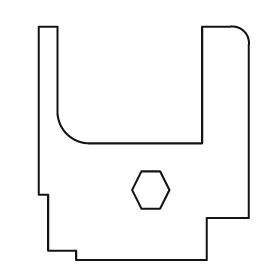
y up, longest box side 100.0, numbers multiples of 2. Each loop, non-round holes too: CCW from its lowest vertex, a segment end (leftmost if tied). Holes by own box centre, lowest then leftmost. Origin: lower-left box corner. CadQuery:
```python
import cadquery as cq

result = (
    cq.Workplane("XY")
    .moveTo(16.0, 0.0)
    .lineTo(72.0, 0.0)
    .lineTo(72.0, 18.0)
    .lineTo(90.0, 18.0)
    .lineTo(90.0, 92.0)
    .threePointArc((88.0, 98.0), (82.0, 100.0))
    .lineTo(70.0, 100.0)
    .lineTo(70.0, 50.0)
    .lineTo(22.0, 50.0)
    .threePointArc((12.0, 54.0), (8.0, 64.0))
    .lineTo(8.0, 100.0)
    .lineTo(0.0, 100.0)
    .lineTo(0.0, 28.0)
    .lineTo(4.0, 28.0)
    .lineTo(4.0, 4.0)
    .lineTo(16.0, 4.0)
    .close()
    .moveTo(44.0, 22.0)
    .lineTo(52.0, 22.0)
    .lineTo(56.0, 30.0)
    .lineTo(52.0, 38.0)
    .lineTo(44.0, 38.0)
    .lineTo(40.0, 30.0)
    .close()
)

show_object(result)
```